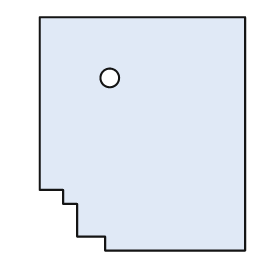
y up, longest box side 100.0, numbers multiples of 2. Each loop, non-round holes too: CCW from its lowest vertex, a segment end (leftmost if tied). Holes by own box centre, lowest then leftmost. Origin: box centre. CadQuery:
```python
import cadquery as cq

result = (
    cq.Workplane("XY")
    .moveTo(-16.0, -50.0)
    .lineTo(44.0, -50.0)
    .lineTo(44.0, 50.0)
    .lineTo(-44.0, 50.0)
    .lineTo(-44.0, -24.0)
    .lineTo(-34.0, -24.0)
    .lineTo(-34.0, -30.0)
    .lineTo(-28.0, -30.0)
    .lineTo(-28.0, -44.0)
    .lineTo(-16.0, -44.0)
    .close()
    .moveTo(-14.0, 24.0)
    .circle(4.0)
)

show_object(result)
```